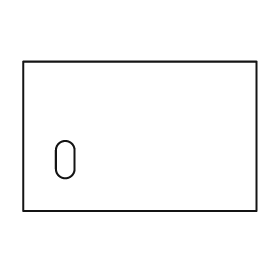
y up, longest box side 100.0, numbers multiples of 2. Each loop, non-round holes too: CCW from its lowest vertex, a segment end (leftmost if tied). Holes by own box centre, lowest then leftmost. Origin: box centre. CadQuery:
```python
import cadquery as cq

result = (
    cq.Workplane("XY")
    .moveTo(-50.0, -32.0)
    .lineTo(50.0, -32.0)
    .lineTo(50.0, 32.0)
    .lineTo(-50.0, 32.0)
    .close()
    .moveTo(-36.0, -14.0)
    .threePointArc((-32.0, -18.0), (-28.0, -14.0))
    .lineTo(-28.0, -6.0)
    .threePointArc((-32.0, -2.0), (-36.0, -6.0))
    .close()
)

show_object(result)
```